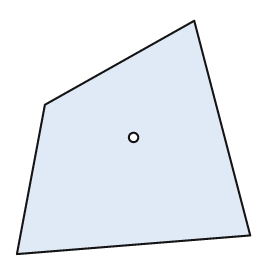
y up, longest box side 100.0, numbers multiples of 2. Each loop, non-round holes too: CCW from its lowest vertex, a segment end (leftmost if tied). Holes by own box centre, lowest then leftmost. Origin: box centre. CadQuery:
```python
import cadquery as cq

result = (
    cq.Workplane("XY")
    .moveTo(-50.0, -50.0)
    .lineTo(50.0, -42.0)
    .lineTo(26.0, 50.0)
    .lineTo(-38.0, 14.0)
    .close()
    .moveTo(0.0, 0.0)
    .circle(2.0)
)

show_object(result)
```